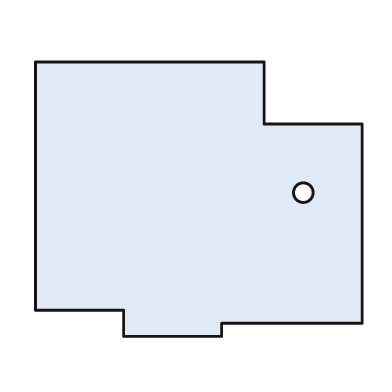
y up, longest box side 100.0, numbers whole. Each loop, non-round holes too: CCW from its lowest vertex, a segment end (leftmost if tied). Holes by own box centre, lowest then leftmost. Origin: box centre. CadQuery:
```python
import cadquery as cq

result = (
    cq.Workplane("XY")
    .moveTo(-23.0, -42.0)
    .lineTo(7.0, -42.0)
    .lineTo(7.0, -38.0)
    .lineTo(50.0, -38.0)
    .lineTo(50.0, 23.0)
    .lineTo(20.0, 23.0)
    .lineTo(20.0, 42.0)
    .lineTo(-50.0, 42.0)
    .lineTo(-50.0, -34.0)
    .lineTo(-23.0, -34.0)
    .close()
    .moveTo(32.0, 2.0)
    .circle(3.0)
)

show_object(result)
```